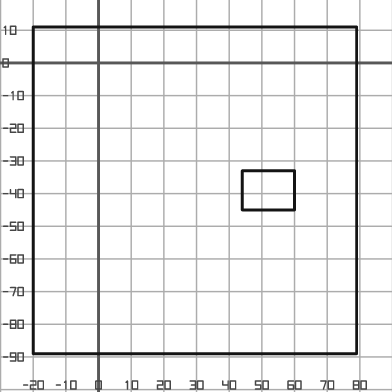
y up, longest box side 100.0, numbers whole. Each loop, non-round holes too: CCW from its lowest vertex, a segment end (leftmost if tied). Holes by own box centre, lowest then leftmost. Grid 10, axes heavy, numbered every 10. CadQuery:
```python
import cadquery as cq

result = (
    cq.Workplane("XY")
    .moveTo(-20.0, -89.0)
    .lineTo(79.0, -89.0)
    .lineTo(79.0, 11.0)
    .lineTo(-20.0, 11.0)
    .close()
    .moveTo(44.0, -45.0)
    .lineTo(60.0, -45.0)
    .lineTo(60.0, -33.0)
    .lineTo(44.0, -33.0)
    .close()
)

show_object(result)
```